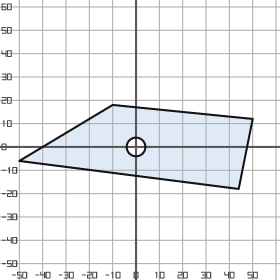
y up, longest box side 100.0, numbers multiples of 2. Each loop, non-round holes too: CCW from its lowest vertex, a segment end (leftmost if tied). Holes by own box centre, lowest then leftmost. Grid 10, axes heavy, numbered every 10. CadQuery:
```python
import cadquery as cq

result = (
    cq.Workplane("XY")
    .moveTo(44.0, -18.0)
    .lineTo(50.0, 12.0)
    .lineTo(-10.0, 18.0)
    .lineTo(-50.0, -6.0)
    .close()
    .moveTo(0.0, 0.0)
    .circle(4.0)
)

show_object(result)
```